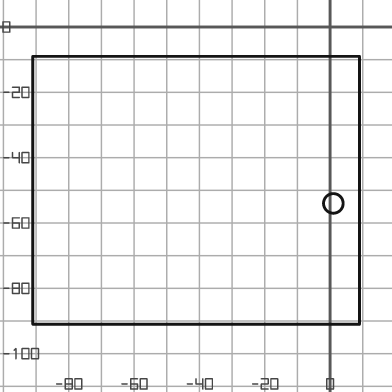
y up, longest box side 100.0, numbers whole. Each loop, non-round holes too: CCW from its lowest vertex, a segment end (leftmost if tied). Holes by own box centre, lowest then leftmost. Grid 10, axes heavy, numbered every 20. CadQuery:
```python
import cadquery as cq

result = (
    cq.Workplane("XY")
    .moveTo(-91.0, -91.0)
    .lineTo(9.0, -91.0)
    .lineTo(9.0, -9.0)
    .lineTo(-91.0, -9.0)
    .close()
    .moveTo(1.0, -54.0)
    .circle(3.0)
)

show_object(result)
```